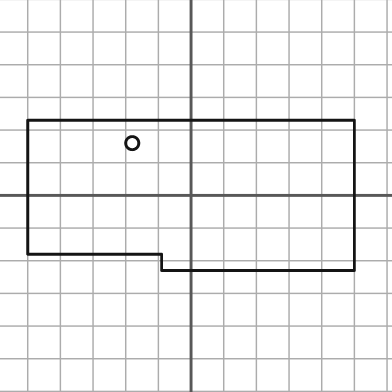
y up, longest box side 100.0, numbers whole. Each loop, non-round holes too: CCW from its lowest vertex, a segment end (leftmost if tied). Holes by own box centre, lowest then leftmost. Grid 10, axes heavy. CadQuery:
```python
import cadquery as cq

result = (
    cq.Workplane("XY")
    .moveTo(-9.0, -23.0)
    .lineTo(50.0, -23.0)
    .lineTo(50.0, 23.0)
    .lineTo(-50.0, 23.0)
    .lineTo(-50.0, -18.0)
    .lineTo(-9.0, -18.0)
    .close()
    .moveTo(-18.0, 16.0)
    .circle(2.0)
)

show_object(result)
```